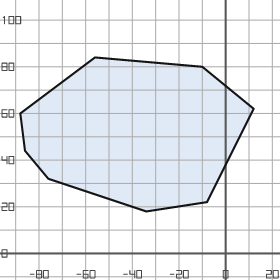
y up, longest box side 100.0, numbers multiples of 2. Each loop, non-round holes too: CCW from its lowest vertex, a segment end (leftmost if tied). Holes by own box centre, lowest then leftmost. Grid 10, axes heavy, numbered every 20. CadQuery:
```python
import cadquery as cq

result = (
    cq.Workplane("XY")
    .moveTo(-34.0, 18.0)
    .lineTo(-8.0, 22.0)
    .lineTo(12.0, 62.0)
    .lineTo(-10.0, 80.0)
    .lineTo(-56.0, 84.0)
    .lineTo(-88.0, 60.0)
    .lineTo(-86.0, 44.0)
    .lineTo(-76.0, 32.0)
    .close()
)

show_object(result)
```